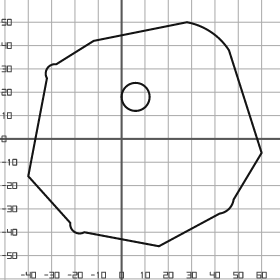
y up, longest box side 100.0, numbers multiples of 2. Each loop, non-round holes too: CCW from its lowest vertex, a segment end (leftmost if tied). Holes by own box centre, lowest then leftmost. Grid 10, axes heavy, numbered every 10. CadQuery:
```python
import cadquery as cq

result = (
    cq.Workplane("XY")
    .moveTo(16.0, -46.0)
    .lineTo(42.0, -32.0)
    .threePointArc((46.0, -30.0), (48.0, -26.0))
    .lineTo(60.0, -6.0)
    .lineTo(46.0, 38.0)
    .threePointArc((38.0, 46.0), (28.0, 50.0))
    .lineTo(-12.0, 42.0)
    .lineTo(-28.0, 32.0)
    .threePointArc((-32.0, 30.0), (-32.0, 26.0))
    .lineTo(-40.0, -16.0)
    .lineTo(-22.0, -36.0)
    .threePointArc((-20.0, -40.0), (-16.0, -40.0))
    .close()
    .moveTo(6.0, 18.0)
    .circle(6.0)
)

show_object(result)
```